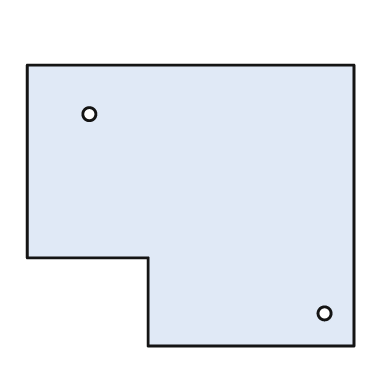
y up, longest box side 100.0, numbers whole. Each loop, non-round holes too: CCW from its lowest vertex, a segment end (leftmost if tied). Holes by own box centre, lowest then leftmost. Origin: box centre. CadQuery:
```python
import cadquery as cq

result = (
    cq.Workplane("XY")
    .moveTo(-13.0, -43.0)
    .lineTo(50.0, -43.0)
    .lineTo(50.0, 43.0)
    .lineTo(-50.0, 43.0)
    .lineTo(-50.0, -16.0)
    .lineTo(-13.0, -16.0)
    .close()
    .moveTo(41.0, -33.0)
    .circle(2.0)
    .moveTo(-31.0, 28.0)
    .circle(2.0)
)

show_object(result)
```